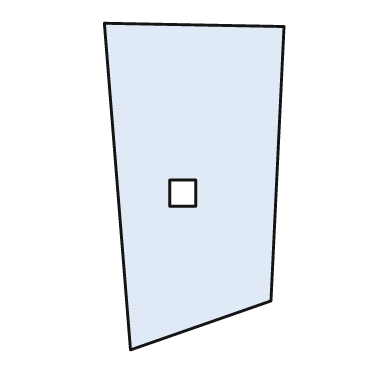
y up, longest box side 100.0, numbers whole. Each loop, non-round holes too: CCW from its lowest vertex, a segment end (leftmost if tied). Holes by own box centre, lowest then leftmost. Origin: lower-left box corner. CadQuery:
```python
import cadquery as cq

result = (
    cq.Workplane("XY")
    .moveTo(8.0, 0.0)
    .lineTo(51.0, 15.0)
    .lineTo(55.0, 99.0)
    .lineTo(0.0, 100.0)
    .close()
    .moveTo(20.0, 44.0)
    .lineTo(28.0, 44.0)
    .lineTo(28.0, 52.0)
    .lineTo(20.0, 52.0)
    .close()
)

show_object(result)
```